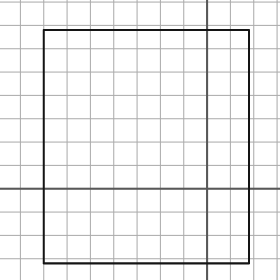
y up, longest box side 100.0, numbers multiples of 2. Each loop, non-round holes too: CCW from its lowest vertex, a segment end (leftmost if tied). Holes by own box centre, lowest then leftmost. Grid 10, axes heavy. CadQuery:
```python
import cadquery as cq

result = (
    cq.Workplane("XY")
    .moveTo(-70.0, -32.0)
    .lineTo(18.0, -32.0)
    .lineTo(18.0, 68.0)
    .lineTo(-70.0, 68.0)
    .close()
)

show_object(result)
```